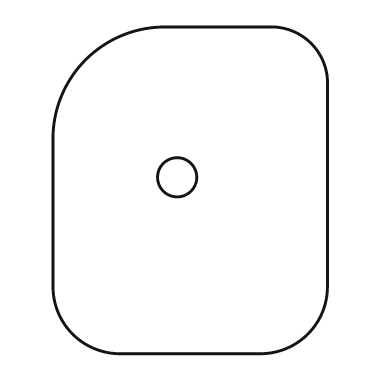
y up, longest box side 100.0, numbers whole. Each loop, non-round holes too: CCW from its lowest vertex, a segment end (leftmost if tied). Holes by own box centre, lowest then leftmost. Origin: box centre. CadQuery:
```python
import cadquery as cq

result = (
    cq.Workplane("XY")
    .moveTo(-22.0, -50.0)
    .lineTo(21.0, -50.0)
    .threePointArc((36.0, -44.0), (42.0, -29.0))
    .lineTo(42.0, 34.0)
    .threePointArc((37.0, 45.0), (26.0, 50.0))
    .lineTo(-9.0, 50.0)
    .threePointArc((-32.0, 40.0), (-42.0, 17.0))
    .lineTo(-42.0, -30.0)
    .threePointArc((-36.0, -44.0), (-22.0, -50.0))
    .close()
    .moveTo(-4.0, 4.0)
    .circle(6.0)
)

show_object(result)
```